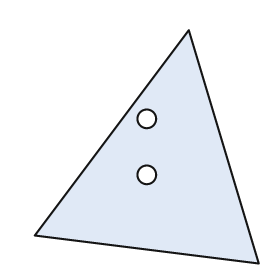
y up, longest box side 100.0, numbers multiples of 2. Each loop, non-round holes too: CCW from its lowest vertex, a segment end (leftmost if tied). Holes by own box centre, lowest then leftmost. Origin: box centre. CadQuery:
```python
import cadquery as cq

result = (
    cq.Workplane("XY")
    .moveTo(48.0, -50.0)
    .lineTo(18.0, 50.0)
    .lineTo(-48.0, -38.0)
    .close()
    .moveTo(0.0, -12.0)
    .circle(4.0)
    .moveTo(0.0, 12.0)
    .circle(4.0)
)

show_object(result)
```